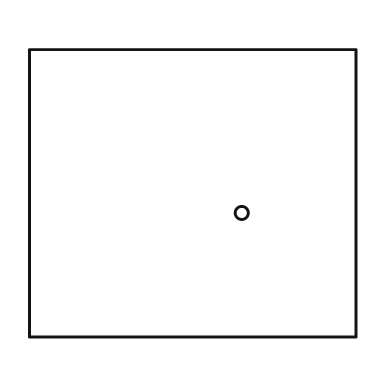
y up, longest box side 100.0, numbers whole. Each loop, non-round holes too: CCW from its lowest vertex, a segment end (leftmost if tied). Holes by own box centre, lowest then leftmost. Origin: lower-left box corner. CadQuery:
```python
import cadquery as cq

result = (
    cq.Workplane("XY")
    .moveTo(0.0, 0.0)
    .lineTo(100.0, 0.0)
    .lineTo(100.0, 88.0)
    .lineTo(0.0, 88.0)
    .close()
    .moveTo(65.0, 38.0)
    .circle(2.0)
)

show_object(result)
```